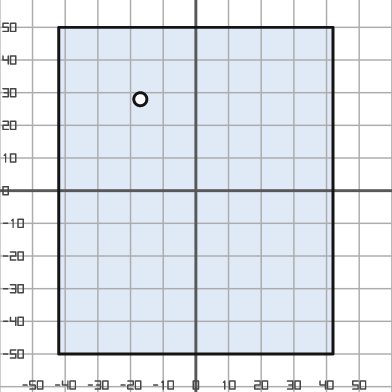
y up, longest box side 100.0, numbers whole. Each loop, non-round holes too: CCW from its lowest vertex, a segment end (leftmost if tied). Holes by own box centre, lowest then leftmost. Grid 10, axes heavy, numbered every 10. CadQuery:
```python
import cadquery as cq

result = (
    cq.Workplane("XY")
    .moveTo(-42.0, -50.0)
    .lineTo(42.0, -50.0)
    .lineTo(42.0, 50.0)
    .lineTo(-42.0, 50.0)
    .close()
    .moveTo(-17.0, 28.0)
    .circle(2.0)
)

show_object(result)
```